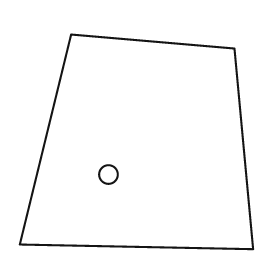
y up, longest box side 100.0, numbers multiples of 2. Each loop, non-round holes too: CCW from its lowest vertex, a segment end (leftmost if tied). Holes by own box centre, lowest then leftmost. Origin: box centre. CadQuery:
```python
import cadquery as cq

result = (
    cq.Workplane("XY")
    .moveTo(50.0, -46.0)
    .lineTo(42.0, 40.0)
    .lineTo(-28.0, 46.0)
    .lineTo(-50.0, -44.0)
    .close()
    .moveTo(-12.0, -14.0)
    .circle(4.0)
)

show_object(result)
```